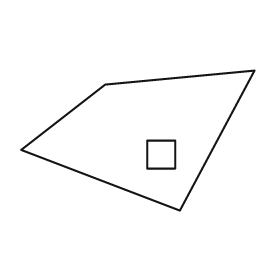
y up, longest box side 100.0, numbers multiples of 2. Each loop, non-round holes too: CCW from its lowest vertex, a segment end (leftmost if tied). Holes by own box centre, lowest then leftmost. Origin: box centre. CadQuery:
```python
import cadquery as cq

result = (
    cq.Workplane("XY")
    .moveTo(18.0, -30.0)
    .lineTo(50.0, 30.0)
    .lineTo(-14.0, 24.0)
    .lineTo(-50.0, -4.0)
    .close()
    .moveTo(4.0, -12.0)
    .lineTo(16.0, -12.0)
    .lineTo(16.0, 0.0)
    .lineTo(4.0, 0.0)
    .close()
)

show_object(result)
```